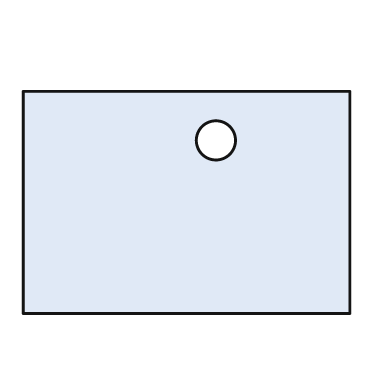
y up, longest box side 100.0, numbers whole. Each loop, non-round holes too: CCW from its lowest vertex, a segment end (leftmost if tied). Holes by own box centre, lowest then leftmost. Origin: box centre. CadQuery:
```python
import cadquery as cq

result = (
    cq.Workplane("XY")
    .moveTo(-50.0, -34.0)
    .lineTo(50.0, -34.0)
    .lineTo(50.0, 34.0)
    .lineTo(-50.0, 34.0)
    .close()
    .moveTo(9.0, 19.0)
    .circle(6.0)
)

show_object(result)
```